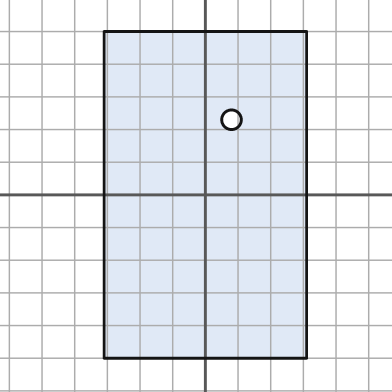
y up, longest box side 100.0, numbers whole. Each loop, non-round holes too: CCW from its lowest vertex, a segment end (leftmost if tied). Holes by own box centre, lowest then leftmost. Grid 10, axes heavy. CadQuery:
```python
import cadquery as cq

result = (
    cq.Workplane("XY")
    .moveTo(-31.0, -50.0)
    .lineTo(31.0, -50.0)
    .lineTo(31.0, 50.0)
    .lineTo(-31.0, 50.0)
    .close()
    .moveTo(8.0, 23.0)
    .circle(3.0)
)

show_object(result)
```